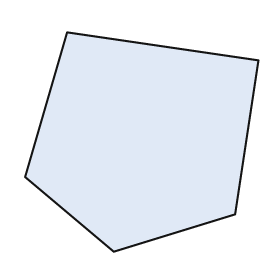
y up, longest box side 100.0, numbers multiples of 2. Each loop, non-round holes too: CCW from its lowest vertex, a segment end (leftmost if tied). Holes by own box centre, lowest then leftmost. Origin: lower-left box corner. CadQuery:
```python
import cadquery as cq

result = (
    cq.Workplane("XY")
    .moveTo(38.0, 0.0)
    .lineTo(90.0, 16.0)
    .lineTo(100.0, 82.0)
    .lineTo(18.0, 94.0)
    .lineTo(0.0, 32.0)
    .close()
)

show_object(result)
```